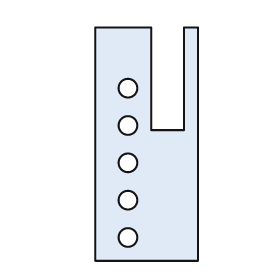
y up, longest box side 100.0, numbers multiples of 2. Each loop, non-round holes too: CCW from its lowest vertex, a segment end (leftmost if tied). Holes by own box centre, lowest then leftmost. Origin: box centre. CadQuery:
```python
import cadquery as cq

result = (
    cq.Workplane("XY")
    .moveTo(-22.0, -50.0)
    .lineTo(22.0, -50.0)
    .lineTo(22.0, 50.0)
    .lineTo(16.0, 50.0)
    .lineTo(16.0, 6.0)
    .lineTo(2.0, 6.0)
    .lineTo(2.0, 50.0)
    .lineTo(-22.0, 50.0)
    .close()
    .moveTo(-8.0, -40.0)
    .circle(4.0)
    .moveTo(-8.0, -24.0)
    .circle(4.0)
    .moveTo(-8.0, -8.0)
    .circle(4.0)
    .moveTo(-8.0, 8.0)
    .circle(4.0)
    .moveTo(-8.0, 24.0)
    .circle(4.0)
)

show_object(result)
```